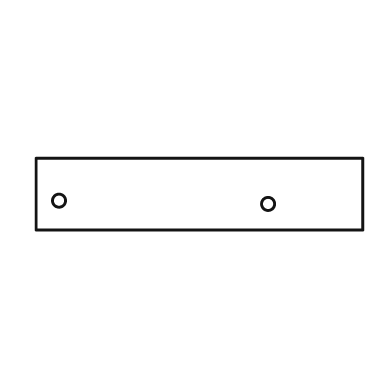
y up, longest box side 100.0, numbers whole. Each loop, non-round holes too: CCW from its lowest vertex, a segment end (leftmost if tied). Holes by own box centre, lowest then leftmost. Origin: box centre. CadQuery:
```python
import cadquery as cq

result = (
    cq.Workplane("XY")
    .moveTo(-50.0, -11.0)
    .lineTo(50.0, -11.0)
    .lineTo(50.0, 11.0)
    .lineTo(-50.0, 11.0)
    .close()
    .moveTo(21.0, -3.0)
    .circle(2.0)
    .moveTo(-43.0, -2.0)
    .circle(2.0)
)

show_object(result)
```